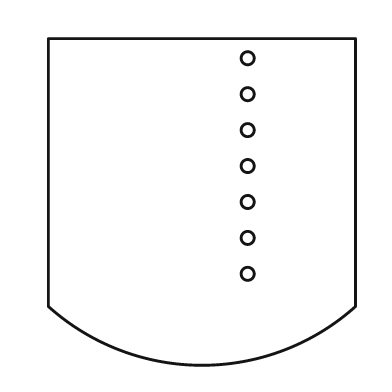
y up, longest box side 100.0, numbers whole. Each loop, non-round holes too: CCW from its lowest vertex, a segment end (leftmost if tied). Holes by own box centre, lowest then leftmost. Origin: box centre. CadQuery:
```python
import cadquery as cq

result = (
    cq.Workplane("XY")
    .moveTo(-47.0, -32.0)
    .threePointArc((0.0, -50.0), (47.0, -32.0))
    .lineTo(47.0, 50.0)
    .lineTo(-47.0, 50.0)
    .close()
    .moveTo(14.0, -22.0)
    .circle(2.0)
    .moveTo(14.0, -11.0)
    .circle(2.0)
    .moveTo(14.0, 0.0)
    .circle(2.0)
    .moveTo(14.0, 11.0)
    .circle(2.0)
    .moveTo(14.0, 22.0)
    .circle(2.0)
    .moveTo(14.0, 33.0)
    .circle(2.0)
    .moveTo(14.0, 44.0)
    .circle(2.0)
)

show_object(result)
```